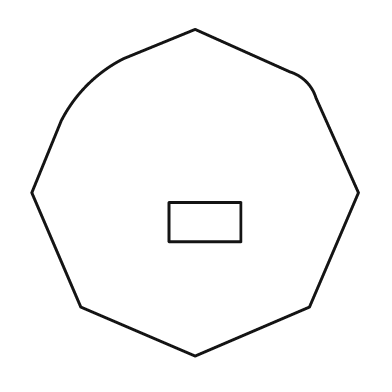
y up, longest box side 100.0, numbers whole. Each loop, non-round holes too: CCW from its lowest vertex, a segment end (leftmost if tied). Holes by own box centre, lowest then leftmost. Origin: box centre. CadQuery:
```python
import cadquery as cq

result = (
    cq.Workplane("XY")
    .moveTo(0.0, -50.0)
    .lineTo(35.0, -35.0)
    .lineTo(50.0, 0.0)
    .lineTo(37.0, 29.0)
    .threePointArc((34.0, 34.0), (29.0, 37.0))
    .lineTo(0.0, 50.0)
    .lineTo(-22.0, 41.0)
    .threePointArc((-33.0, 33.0), (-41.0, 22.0))
    .lineTo(-50.0, 0.0)
    .lineTo(-35.0, -35.0)
    .close()
    .moveTo(-8.0, -15.0)
    .lineTo(14.0, -15.0)
    .lineTo(14.0, -3.0)
    .lineTo(-8.0, -3.0)
    .close()
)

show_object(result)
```